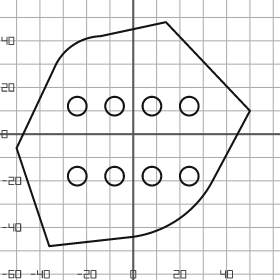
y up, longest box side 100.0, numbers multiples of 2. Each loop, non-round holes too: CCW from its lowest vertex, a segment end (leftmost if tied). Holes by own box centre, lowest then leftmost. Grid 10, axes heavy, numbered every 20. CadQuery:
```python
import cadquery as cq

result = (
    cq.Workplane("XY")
    .moveTo(-36.0, -48.0)
    .lineTo(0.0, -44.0)
    .threePointArc((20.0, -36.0), (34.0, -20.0))
    .lineTo(50.0, 10.0)
    .lineTo(14.0, 48.0)
    .lineTo(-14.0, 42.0)
    .threePointArc((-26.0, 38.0), (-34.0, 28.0))
    .lineTo(-50.0, -6.0)
    .close()
    .moveTo(-24.0, -18.0)
    .circle(4.0)
    .moveTo(-8.0, -18.0)
    .circle(4.0)
    .moveTo(8.0, -18.0)
    .circle(4.0)
    .moveTo(24.0, -18.0)
    .circle(4.0)
    .moveTo(-24.0, 12.0)
    .circle(4.0)
    .moveTo(-8.0, 12.0)
    .circle(4.0)
    .moveTo(8.0, 12.0)
    .circle(4.0)
    .moveTo(24.0, 12.0)
    .circle(4.0)
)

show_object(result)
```